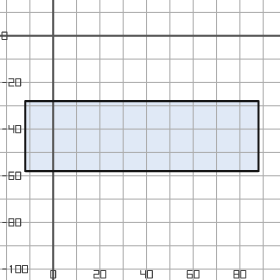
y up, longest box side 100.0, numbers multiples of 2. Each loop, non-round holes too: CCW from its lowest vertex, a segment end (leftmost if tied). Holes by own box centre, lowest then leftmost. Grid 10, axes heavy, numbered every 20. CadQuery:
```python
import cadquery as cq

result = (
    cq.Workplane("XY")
    .moveTo(-12.0, -58.0)
    .lineTo(88.0, -58.0)
    .lineTo(88.0, -28.0)
    .lineTo(-12.0, -28.0)
    .close()
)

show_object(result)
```